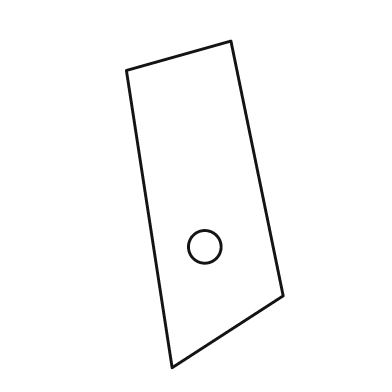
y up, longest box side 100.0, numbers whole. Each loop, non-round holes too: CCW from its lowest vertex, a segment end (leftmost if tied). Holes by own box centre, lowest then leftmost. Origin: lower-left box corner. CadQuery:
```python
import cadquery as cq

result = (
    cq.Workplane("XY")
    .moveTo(14.0, 0.0)
    .lineTo(48.0, 22.0)
    .lineTo(32.0, 100.0)
    .lineTo(0.0, 91.0)
    .close()
    .moveTo(24.0, 37.0)
    .circle(5.0)
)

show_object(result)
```